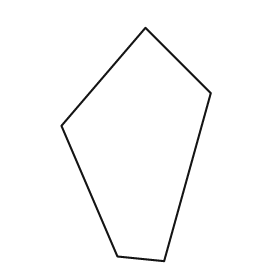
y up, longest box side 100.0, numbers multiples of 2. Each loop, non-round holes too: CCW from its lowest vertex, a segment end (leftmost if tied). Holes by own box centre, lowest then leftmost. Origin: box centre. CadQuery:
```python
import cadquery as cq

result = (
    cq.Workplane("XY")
    .moveTo(12.0, -50.0)
    .lineTo(32.0, 22.0)
    .lineTo(4.0, 50.0)
    .lineTo(-32.0, 8.0)
    .lineTo(-8.0, -48.0)
    .close()
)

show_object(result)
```